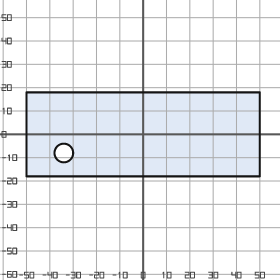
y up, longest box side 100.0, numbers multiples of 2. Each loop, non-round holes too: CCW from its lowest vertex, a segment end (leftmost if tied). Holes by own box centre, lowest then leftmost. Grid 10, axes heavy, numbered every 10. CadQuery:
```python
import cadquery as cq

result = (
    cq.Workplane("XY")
    .moveTo(-50.0, -18.0)
    .lineTo(50.0, -18.0)
    .lineTo(50.0, 18.0)
    .lineTo(-50.0, 18.0)
    .close()
    .moveTo(-34.0, -8.0)
    .circle(4.0)
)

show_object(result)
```